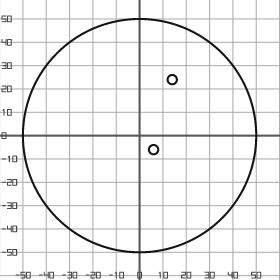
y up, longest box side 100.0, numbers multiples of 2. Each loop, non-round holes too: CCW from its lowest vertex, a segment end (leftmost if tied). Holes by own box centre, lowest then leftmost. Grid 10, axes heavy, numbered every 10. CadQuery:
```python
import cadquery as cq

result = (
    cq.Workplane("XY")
    .moveTo(0.0, 0.0)
    .circle(50.0)
    .moveTo(6.0, -6.0)
    .circle(2.0)
    .moveTo(14.0, 24.0)
    .circle(2.0)
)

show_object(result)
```